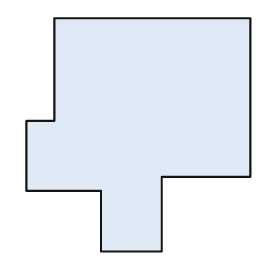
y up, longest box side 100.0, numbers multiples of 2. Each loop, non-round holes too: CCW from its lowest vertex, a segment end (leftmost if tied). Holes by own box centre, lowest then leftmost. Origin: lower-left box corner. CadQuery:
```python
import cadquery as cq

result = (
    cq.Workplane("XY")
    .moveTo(32.0, 0.0)
    .lineTo(58.0, 0.0)
    .lineTo(58.0, 32.0)
    .lineTo(96.0, 32.0)
    .lineTo(96.0, 100.0)
    .lineTo(12.0, 100.0)
    .lineTo(12.0, 56.0)
    .lineTo(0.0, 56.0)
    .lineTo(0.0, 26.0)
    .lineTo(32.0, 26.0)
    .close()
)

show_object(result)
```